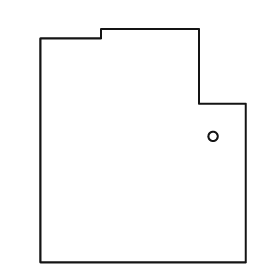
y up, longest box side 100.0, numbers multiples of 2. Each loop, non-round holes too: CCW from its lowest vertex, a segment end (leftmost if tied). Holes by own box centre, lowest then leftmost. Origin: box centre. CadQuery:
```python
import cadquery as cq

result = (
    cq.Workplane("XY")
    .moveTo(-44.0, -50.0)
    .lineTo(44.0, -50.0)
    .lineTo(44.0, 18.0)
    .lineTo(24.0, 18.0)
    .lineTo(24.0, 50.0)
    .lineTo(-18.0, 50.0)
    .lineTo(-18.0, 46.0)
    .lineTo(-44.0, 46.0)
    .close()
    .moveTo(30.0, 4.0)
    .circle(2.0)
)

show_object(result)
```